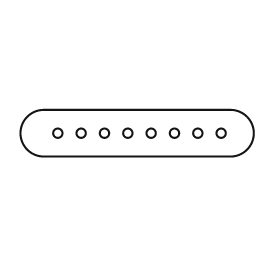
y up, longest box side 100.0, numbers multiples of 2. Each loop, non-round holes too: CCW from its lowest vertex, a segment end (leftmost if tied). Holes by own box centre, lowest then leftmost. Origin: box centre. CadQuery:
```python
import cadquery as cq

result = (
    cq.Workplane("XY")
    .moveTo(-40.0, -10.0)
    .lineTo(40.0, -10.0)
    .threePointArc((50.0, 0.0), (40.0, 10.0))
    .lineTo(-40.0, 10.0)
    .threePointArc((-50.0, 0.0), (-40.0, -10.0))
    .close()
    .moveTo(-34.0, 0.0)
    .circle(2.0)
    .moveTo(-24.0, 0.0)
    .circle(2.0)
    .moveTo(-14.0, 0.0)
    .circle(2.0)
    .moveTo(-4.0, 0.0)
    .circle(2.0)
    .moveTo(6.0, 0.0)
    .circle(2.0)
    .moveTo(16.0, 0.0)
    .circle(2.0)
    .moveTo(26.0, 0.0)
    .circle(2.0)
    .moveTo(36.0, 0.0)
    .circle(2.0)
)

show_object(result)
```